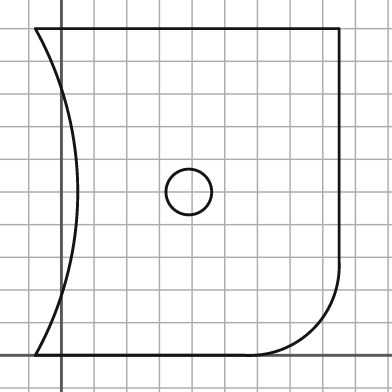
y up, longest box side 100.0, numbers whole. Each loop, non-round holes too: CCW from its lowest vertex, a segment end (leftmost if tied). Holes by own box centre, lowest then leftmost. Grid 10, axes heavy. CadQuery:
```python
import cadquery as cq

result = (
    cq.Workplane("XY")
    .moveTo(-8.0, 0.0)
    .lineTo(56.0, 0.0)
    .threePointArc((77.0, 8.0), (85.0, 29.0))
    .lineTo(85.0, 100.0)
    .lineTo(-8.0, 100.0)
    .threePointArc((5.0, 50.0), (-8.0, 0.0))
    .close()
    .moveTo(39.0, 50.0)
    .circle(7.0)
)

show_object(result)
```